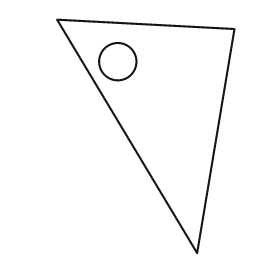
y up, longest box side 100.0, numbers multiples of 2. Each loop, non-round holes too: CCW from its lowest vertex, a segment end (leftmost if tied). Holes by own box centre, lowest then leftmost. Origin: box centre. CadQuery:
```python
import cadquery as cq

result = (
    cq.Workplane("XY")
    .moveTo(22.0, -50.0)
    .lineTo(38.0, 46.0)
    .lineTo(-38.0, 50.0)
    .close()
    .moveTo(-12.0, 32.0)
    .circle(8.0)
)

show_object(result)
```